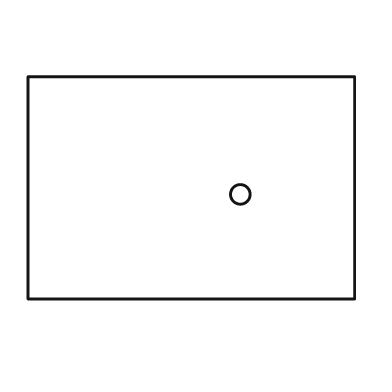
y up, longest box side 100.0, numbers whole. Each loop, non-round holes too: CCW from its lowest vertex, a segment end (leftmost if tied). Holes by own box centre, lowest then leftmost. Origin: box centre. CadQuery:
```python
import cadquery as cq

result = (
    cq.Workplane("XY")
    .moveTo(-50.0, -34.0)
    .lineTo(50.0, -34.0)
    .lineTo(50.0, 34.0)
    .lineTo(-50.0, 34.0)
    .close()
    .moveTo(15.0, -2.0)
    .circle(3.0)
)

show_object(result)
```